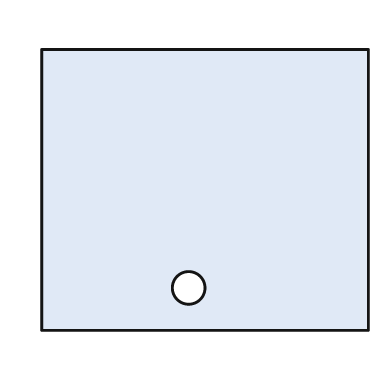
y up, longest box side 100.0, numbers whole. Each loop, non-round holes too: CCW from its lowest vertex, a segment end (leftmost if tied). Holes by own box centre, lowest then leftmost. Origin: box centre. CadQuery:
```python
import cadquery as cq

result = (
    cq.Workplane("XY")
    .moveTo(-50.0, -43.0)
    .lineTo(50.0, -43.0)
    .lineTo(50.0, 43.0)
    .lineTo(-50.0, 43.0)
    .close()
    .moveTo(-5.0, -30.0)
    .circle(5.0)
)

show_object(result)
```